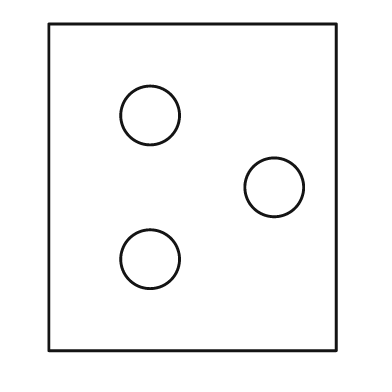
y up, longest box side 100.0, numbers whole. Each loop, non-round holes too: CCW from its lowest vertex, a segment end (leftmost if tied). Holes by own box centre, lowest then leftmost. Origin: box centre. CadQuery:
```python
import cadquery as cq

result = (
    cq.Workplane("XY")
    .moveTo(-44.0, -50.0)
    .lineTo(44.0, -50.0)
    .lineTo(44.0, 50.0)
    .lineTo(-44.0, 50.0)
    .close()
    .moveTo(-13.0, -22.0)
    .circle(9.0)
    .moveTo(25.0, 0.0)
    .circle(9.0)
    .moveTo(-13.0, 22.0)
    .circle(9.0)
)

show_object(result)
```